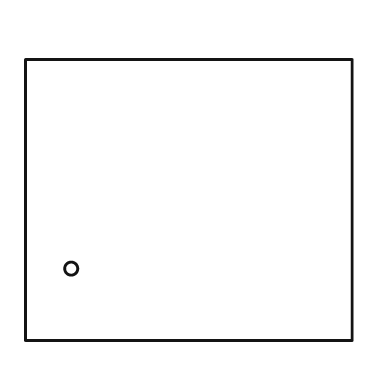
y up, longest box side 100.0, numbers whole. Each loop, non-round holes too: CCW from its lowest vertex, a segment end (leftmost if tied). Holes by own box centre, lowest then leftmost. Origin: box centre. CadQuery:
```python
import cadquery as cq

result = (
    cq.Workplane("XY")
    .moveTo(-50.0, -43.0)
    .lineTo(50.0, -43.0)
    .lineTo(50.0, 43.0)
    .lineTo(-50.0, 43.0)
    .close()
    .moveTo(-36.0, -21.0)
    .circle(2.0)
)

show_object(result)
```